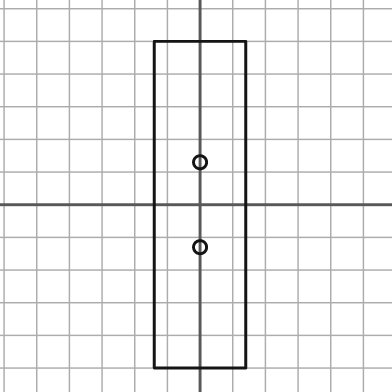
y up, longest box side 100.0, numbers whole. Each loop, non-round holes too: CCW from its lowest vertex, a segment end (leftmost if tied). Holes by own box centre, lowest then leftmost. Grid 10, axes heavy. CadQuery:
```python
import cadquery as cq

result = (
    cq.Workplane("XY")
    .moveTo(-14.0, -50.0)
    .lineTo(14.0, -50.0)
    .lineTo(14.0, 50.0)
    .lineTo(-14.0, 50.0)
    .close()
    .moveTo(0.0, -13.0)
    .circle(2.0)
    .moveTo(0.0, 13.0)
    .circle(2.0)
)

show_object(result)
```